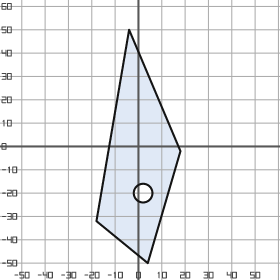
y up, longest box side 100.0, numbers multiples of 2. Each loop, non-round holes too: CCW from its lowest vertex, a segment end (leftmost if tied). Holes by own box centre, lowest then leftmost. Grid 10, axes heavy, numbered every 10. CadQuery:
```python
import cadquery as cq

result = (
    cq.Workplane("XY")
    .moveTo(4.0, -50.0)
    .lineTo(18.0, -2.0)
    .lineTo(-4.0, 50.0)
    .lineTo(-18.0, -32.0)
    .close()
    .moveTo(2.0, -20.0)
    .circle(4.0)
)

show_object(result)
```